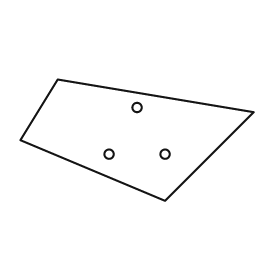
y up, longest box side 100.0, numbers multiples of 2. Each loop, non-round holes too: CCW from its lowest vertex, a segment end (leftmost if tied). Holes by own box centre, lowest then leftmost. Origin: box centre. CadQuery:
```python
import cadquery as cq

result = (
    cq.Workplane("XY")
    .moveTo(12.0, -26.0)
    .lineTo(50.0, 12.0)
    .lineTo(-34.0, 26.0)
    .lineTo(-50.0, 0.0)
    .close()
    .moveTo(-12.0, -6.0)
    .circle(2.0)
    .moveTo(12.0, -6.0)
    .circle(2.0)
    .moveTo(0.0, 14.0)
    .circle(2.0)
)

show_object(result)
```